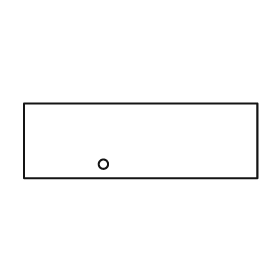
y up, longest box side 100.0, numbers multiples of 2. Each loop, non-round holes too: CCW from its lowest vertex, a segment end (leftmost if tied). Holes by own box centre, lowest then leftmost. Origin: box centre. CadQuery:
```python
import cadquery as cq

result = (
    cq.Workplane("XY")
    .moveTo(-50.0, -16.0)
    .lineTo(50.0, -16.0)
    .lineTo(50.0, 16.0)
    .lineTo(-50.0, 16.0)
    .close()
    .moveTo(-16.0, -10.0)
    .circle(2.0)
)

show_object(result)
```